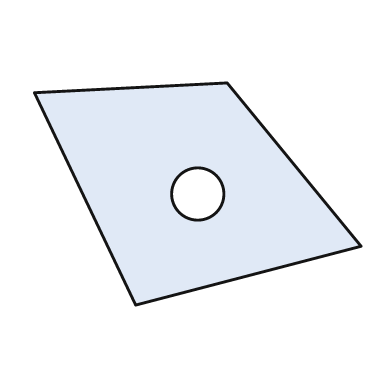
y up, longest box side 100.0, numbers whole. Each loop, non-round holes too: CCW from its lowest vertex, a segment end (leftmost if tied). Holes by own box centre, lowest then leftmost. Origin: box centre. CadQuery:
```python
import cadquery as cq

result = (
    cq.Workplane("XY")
    .moveTo(-19.0, -34.0)
    .lineTo(50.0, -16.0)
    .lineTo(9.0, 34.0)
    .lineTo(-50.0, 31.0)
    .close()
    .moveTo(0.0, 0.0)
    .circle(8.0)
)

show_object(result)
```